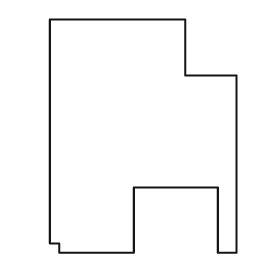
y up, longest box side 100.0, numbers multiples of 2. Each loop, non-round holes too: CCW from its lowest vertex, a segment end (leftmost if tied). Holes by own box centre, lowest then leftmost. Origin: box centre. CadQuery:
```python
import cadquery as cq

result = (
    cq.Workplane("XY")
    .moveTo(-36.0, -50.0)
    .lineTo(-4.0, -50.0)
    .lineTo(-4.0, -22.0)
    .lineTo(32.0, -22.0)
    .lineTo(32.0, -50.0)
    .lineTo(40.0, -50.0)
    .lineTo(40.0, 26.0)
    .lineTo(18.0, 26.0)
    .lineTo(18.0, 50.0)
    .lineTo(-40.0, 50.0)
    .lineTo(-40.0, -46.0)
    .lineTo(-36.0, -46.0)
    .close()
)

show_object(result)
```